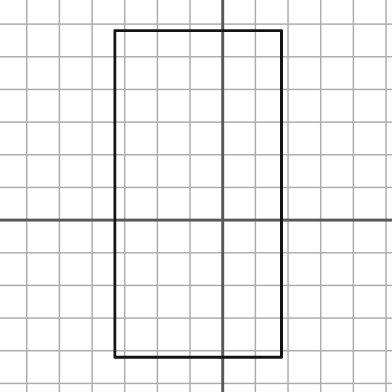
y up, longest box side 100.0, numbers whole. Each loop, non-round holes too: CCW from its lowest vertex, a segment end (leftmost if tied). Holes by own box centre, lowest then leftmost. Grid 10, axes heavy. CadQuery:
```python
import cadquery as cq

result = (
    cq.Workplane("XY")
    .moveTo(-33.0, -42.0)
    .lineTo(18.0, -42.0)
    .lineTo(18.0, 58.0)
    .lineTo(-33.0, 58.0)
    .close()
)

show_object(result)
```